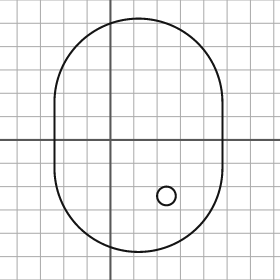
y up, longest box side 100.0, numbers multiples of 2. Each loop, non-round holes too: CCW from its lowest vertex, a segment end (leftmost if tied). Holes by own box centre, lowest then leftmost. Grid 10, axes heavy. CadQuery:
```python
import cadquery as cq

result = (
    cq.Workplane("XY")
    .moveTo(-24.0, -12.0)
    .threePointArc((12.0, -48.0), (48.0, -12.0))
    .lineTo(48.0, 16.0)
    .threePointArc((12.0, 52.0), (-24.0, 16.0))
    .close()
    .moveTo(24.0, -24.0)
    .circle(4.0)
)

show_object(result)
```